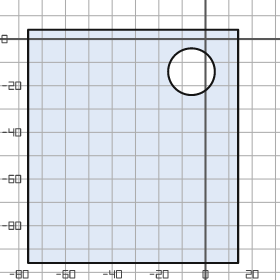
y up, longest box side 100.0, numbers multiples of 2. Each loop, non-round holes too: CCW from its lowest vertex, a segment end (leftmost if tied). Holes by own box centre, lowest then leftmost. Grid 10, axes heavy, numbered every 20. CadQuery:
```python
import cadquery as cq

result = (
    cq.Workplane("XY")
    .moveTo(-76.0, -96.0)
    .lineTo(14.0, -96.0)
    .lineTo(14.0, 4.0)
    .lineTo(-76.0, 4.0)
    .close()
    .moveTo(-6.0, -14.0)
    .circle(10.0)
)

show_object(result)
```